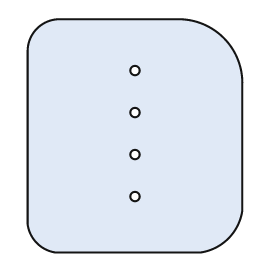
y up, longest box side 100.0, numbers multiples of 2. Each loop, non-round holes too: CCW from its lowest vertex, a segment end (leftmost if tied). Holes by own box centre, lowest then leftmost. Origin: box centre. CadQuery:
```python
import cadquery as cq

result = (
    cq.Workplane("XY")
    .moveTo(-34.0, -50.0)
    .lineTo(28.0, -50.0)
    .threePointArc((40.0, -44.0), (46.0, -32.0))
    .lineTo(46.0, 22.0)
    .threePointArc((38.0, 42.0), (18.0, 50.0))
    .lineTo(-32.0, 50.0)
    .threePointArc((-42.0, 46.0), (-46.0, 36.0))
    .lineTo(-46.0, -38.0)
    .threePointArc((-42.0, -46.0), (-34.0, -50.0))
    .close()
    .moveTo(0.0, -26.0)
    .circle(2.0)
    .moveTo(0.0, -8.0)
    .circle(2.0)
    .moveTo(0.0, 10.0)
    .circle(2.0)
    .moveTo(0.0, 28.0)
    .circle(2.0)
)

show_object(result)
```